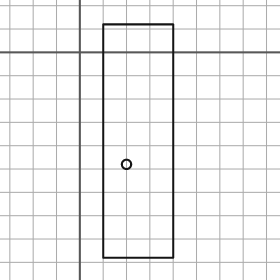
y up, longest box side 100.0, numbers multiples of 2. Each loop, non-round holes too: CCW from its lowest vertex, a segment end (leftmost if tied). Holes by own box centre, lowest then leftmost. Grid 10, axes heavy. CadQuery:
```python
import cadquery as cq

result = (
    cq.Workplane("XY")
    .moveTo(10.0, -88.0)
    .lineTo(40.0, -88.0)
    .lineTo(40.0, 12.0)
    .lineTo(10.0, 12.0)
    .close()
    .moveTo(20.0, -48.0)
    .circle(2.0)
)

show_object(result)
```